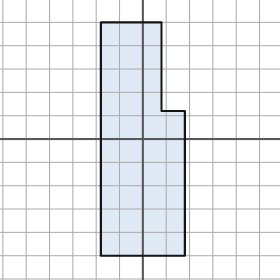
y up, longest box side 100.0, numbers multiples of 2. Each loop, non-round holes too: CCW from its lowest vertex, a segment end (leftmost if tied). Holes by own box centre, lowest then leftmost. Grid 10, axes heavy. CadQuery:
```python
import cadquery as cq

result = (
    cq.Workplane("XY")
    .moveTo(-18.0, -50.0)
    .lineTo(18.0, -50.0)
    .lineTo(18.0, 12.0)
    .lineTo(8.0, 12.0)
    .lineTo(8.0, 50.0)
    .lineTo(-18.0, 50.0)
    .close()
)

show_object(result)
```